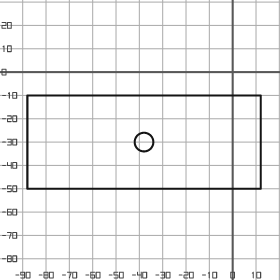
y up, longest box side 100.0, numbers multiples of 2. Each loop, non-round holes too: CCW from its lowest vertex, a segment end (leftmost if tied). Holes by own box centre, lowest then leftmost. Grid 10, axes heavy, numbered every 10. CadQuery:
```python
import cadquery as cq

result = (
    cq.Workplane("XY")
    .moveTo(-88.0, -50.0)
    .lineTo(12.0, -50.0)
    .lineTo(12.0, -10.0)
    .lineTo(-88.0, -10.0)
    .close()
    .moveTo(-38.0, -30.0)
    .circle(4.0)
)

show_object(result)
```